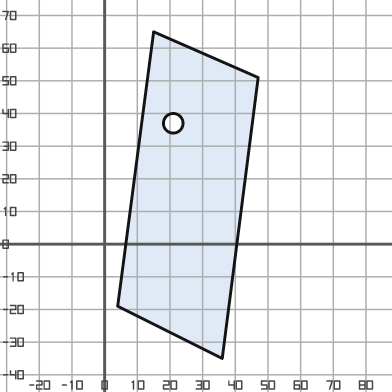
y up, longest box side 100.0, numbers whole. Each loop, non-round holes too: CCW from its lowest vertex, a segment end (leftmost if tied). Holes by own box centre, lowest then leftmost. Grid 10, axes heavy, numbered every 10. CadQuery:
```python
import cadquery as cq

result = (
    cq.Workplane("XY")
    .moveTo(36.0, -35.0)
    .lineTo(47.0, 51.0)
    .lineTo(15.0, 65.0)
    .lineTo(4.0, -19.0)
    .close()
    .moveTo(21.0, 37.0)
    .circle(3.0)
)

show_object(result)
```